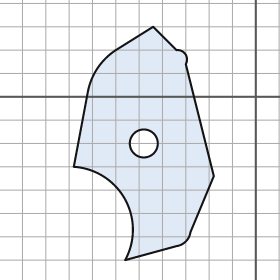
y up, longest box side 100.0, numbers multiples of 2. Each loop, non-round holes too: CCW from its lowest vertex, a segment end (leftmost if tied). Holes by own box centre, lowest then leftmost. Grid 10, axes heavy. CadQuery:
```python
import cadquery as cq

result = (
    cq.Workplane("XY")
    .moveTo(-56.0, -70.0)
    .lineTo(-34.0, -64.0)
    .threePointArc((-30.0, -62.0), (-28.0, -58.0))
    .lineTo(-18.0, -34.0)
    .lineTo(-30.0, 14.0)
    .threePointArc((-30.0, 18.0), (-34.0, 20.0))
    .lineTo(-44.0, 30.0)
    .lineTo(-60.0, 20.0)
    .threePointArc((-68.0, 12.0), (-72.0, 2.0))
    .lineTo(-78.0, -30.0)
    .threePointArc((-56.0, -44.0), (-56.0, -70.0))
    .close()
    .moveTo(-48.0, -20.0)
    .circle(6.0)
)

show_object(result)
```